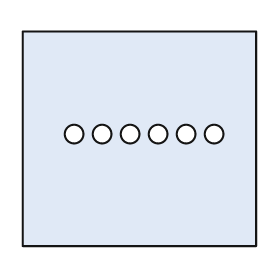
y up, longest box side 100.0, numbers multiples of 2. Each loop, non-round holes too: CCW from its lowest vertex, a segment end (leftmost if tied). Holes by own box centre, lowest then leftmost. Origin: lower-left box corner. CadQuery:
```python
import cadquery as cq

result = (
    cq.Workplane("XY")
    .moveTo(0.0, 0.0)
    .lineTo(100.0, 0.0)
    .lineTo(100.0, 92.0)
    .lineTo(0.0, 92.0)
    .close()
    .moveTo(22.0, 48.0)
    .circle(4.0)
    .moveTo(34.0, 48.0)
    .circle(4.0)
    .moveTo(46.0, 48.0)
    .circle(4.0)
    .moveTo(58.0, 48.0)
    .circle(4.0)
    .moveTo(70.0, 48.0)
    .circle(4.0)
    .moveTo(82.0, 48.0)
    .circle(4.0)
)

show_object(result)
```